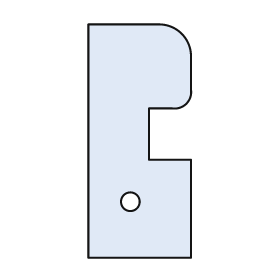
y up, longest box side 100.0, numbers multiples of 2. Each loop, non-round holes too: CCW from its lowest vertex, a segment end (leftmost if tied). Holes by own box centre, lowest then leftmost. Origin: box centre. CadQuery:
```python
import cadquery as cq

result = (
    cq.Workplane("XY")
    .moveTo(-22.0, -50.0)
    .lineTo(22.0, -50.0)
    .lineTo(22.0, -8.0)
    .lineTo(4.0, -8.0)
    .lineTo(4.0, 14.0)
    .lineTo(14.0, 14.0)
    .threePointArc((20.0, 16.0), (22.0, 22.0))
    .lineTo(22.0, 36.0)
    .threePointArc((18.0, 46.0), (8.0, 50.0))
    .lineTo(-22.0, 50.0)
    .close()
    .moveTo(-4.0, -26.0)
    .circle(4.0)
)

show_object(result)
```